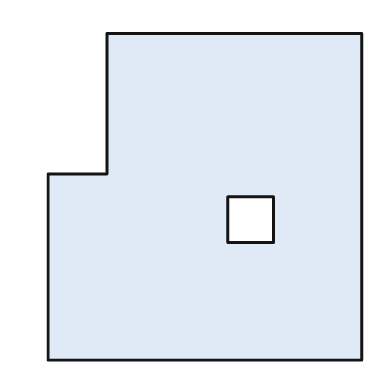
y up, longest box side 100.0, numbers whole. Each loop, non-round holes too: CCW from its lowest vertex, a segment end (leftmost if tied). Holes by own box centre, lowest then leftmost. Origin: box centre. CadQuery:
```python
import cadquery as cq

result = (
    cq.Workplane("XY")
    .moveTo(-48.0, -50.0)
    .lineTo(48.0, -50.0)
    .lineTo(48.0, 50.0)
    .lineTo(-30.0, 50.0)
    .lineTo(-30.0, 7.0)
    .lineTo(-48.0, 7.0)
    .close()
    .moveTo(7.0, -14.0)
    .lineTo(21.0, -14.0)
    .lineTo(21.0, 0.0)
    .lineTo(7.0, 0.0)
    .close()
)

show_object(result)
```